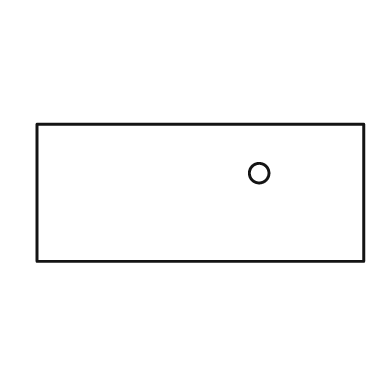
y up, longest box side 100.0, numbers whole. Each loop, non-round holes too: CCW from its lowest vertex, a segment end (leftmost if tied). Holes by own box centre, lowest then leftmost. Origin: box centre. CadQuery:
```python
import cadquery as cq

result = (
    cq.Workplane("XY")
    .moveTo(-50.0, -21.0)
    .lineTo(50.0, -21.0)
    .lineTo(50.0, 21.0)
    .lineTo(-50.0, 21.0)
    .close()
    .moveTo(18.0, 6.0)
    .circle(3.0)
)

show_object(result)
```